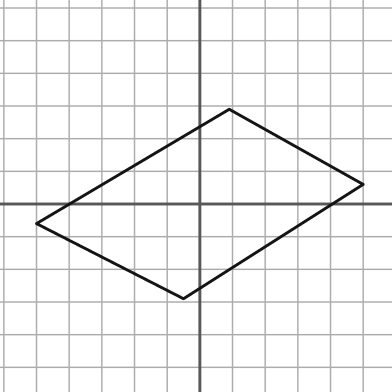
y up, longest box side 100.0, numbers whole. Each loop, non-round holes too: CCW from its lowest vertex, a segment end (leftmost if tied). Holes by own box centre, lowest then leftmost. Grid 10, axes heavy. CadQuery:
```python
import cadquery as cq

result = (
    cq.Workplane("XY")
    .moveTo(-5.0, -29.0)
    .lineTo(50.0, 6.0)
    .lineTo(9.0, 29.0)
    .lineTo(-50.0, -6.0)
    .close()
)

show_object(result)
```